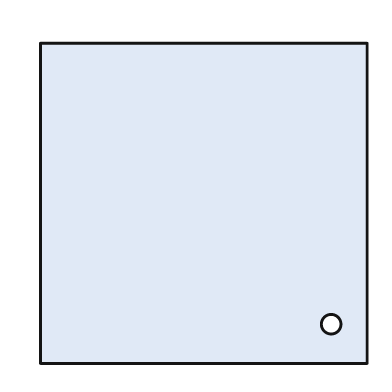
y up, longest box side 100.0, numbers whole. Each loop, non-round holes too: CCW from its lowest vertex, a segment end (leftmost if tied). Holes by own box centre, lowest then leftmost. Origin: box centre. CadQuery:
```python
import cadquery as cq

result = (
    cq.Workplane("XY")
    .moveTo(-50.0, -49.0)
    .lineTo(50.0, -49.0)
    .lineTo(50.0, 49.0)
    .lineTo(-50.0, 49.0)
    .close()
    .moveTo(39.0, -37.0)
    .circle(3.0)
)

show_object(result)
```